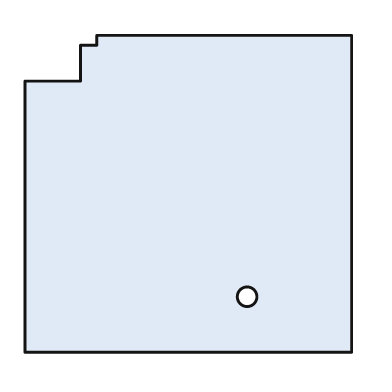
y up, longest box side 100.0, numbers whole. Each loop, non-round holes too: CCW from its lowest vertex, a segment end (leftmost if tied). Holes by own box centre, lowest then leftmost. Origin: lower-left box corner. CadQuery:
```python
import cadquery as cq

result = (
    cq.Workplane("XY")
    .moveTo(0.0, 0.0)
    .lineTo(100.0, 0.0)
    .lineTo(100.0, 97.0)
    .lineTo(22.0, 97.0)
    .lineTo(22.0, 94.0)
    .lineTo(17.0, 94.0)
    .lineTo(17.0, 83.0)
    .lineTo(0.0, 83.0)
    .close()
    .moveTo(68.0, 17.0)
    .circle(3.0)
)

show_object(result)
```